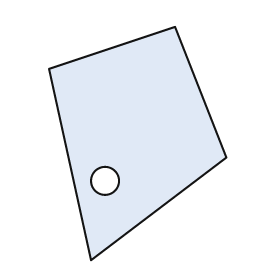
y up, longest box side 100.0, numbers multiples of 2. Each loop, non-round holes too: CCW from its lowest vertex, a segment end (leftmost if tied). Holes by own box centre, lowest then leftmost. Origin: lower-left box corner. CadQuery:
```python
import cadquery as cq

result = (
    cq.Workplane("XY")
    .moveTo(18.0, 0.0)
    .lineTo(76.0, 44.0)
    .lineTo(54.0, 100.0)
    .lineTo(0.0, 82.0)
    .close()
    .moveTo(24.0, 34.0)
    .circle(6.0)
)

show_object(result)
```